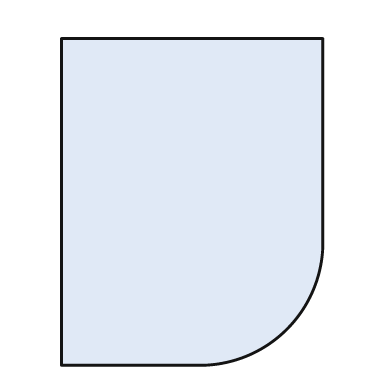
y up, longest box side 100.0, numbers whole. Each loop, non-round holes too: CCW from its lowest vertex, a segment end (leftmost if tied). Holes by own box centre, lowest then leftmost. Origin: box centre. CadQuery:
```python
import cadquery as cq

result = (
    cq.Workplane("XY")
    .moveTo(-40.0, -50.0)
    .lineTo(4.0, -50.0)
    .threePointArc((29.0, -39.0), (40.0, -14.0))
    .lineTo(40.0, 50.0)
    .lineTo(-40.0, 50.0)
    .close()
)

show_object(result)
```